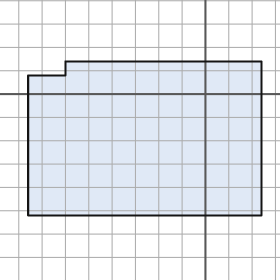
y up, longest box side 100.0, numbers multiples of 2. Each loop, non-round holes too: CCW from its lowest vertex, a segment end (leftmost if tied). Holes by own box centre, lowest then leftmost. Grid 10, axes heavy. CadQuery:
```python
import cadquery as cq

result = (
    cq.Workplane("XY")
    .moveTo(-76.0, -52.0)
    .lineTo(24.0, -52.0)
    .lineTo(24.0, 14.0)
    .lineTo(-60.0, 14.0)
    .lineTo(-60.0, 8.0)
    .lineTo(-76.0, 8.0)
    .close()
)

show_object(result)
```